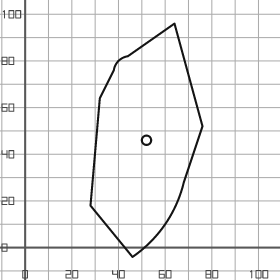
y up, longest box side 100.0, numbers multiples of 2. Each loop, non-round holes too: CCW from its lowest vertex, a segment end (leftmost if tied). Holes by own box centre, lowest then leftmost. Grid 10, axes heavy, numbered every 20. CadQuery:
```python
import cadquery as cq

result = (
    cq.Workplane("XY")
    .moveTo(46.0, -4.0)
    .threePointArc((60.0, 10.0), (68.0, 28.0))
    .lineTo(76.0, 52.0)
    .lineTo(64.0, 96.0)
    .lineTo(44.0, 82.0)
    .threePointArc((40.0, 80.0), (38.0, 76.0))
    .lineTo(32.0, 64.0)
    .lineTo(28.0, 18.0)
    .close()
    .moveTo(52.0, 46.0)
    .circle(2.0)
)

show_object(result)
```